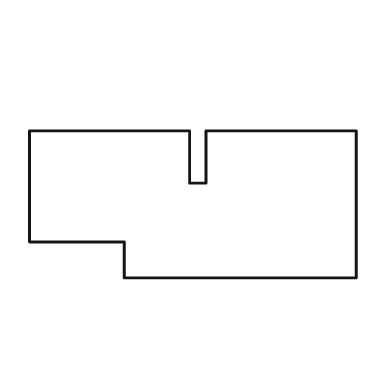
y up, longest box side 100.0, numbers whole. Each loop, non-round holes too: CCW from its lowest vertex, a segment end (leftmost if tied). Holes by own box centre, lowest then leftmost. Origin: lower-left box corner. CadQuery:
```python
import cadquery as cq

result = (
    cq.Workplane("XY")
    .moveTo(29.0, 0.0)
    .lineTo(100.0, 0.0)
    .lineTo(100.0, 45.0)
    .lineTo(54.0, 45.0)
    .lineTo(54.0, 29.0)
    .lineTo(49.0, 29.0)
    .lineTo(49.0, 45.0)
    .lineTo(0.0, 45.0)
    .lineTo(0.0, 11.0)
    .lineTo(29.0, 11.0)
    .close()
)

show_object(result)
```